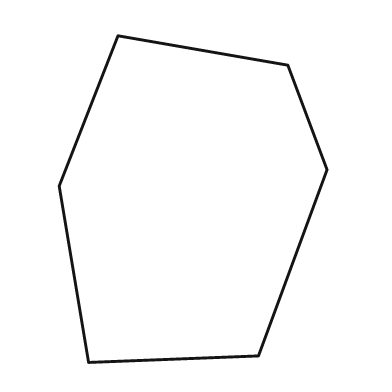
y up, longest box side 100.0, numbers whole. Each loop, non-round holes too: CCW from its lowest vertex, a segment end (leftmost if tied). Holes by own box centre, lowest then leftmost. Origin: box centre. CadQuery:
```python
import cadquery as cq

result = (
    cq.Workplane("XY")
    .moveTo(-32.0, -50.0)
    .lineTo(20.0, -48.0)
    .lineTo(41.0, 9.0)
    .lineTo(29.0, 41.0)
    .lineTo(-23.0, 50.0)
    .lineTo(-41.0, 4.0)
    .close()
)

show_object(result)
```